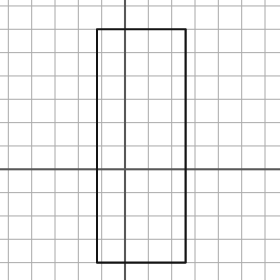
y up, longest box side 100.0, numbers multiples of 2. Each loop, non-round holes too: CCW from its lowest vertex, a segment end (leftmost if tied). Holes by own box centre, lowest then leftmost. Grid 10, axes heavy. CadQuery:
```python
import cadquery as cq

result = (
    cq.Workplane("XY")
    .moveTo(-12.0, -40.0)
    .lineTo(26.0, -40.0)
    .lineTo(26.0, 60.0)
    .lineTo(-12.0, 60.0)
    .close()
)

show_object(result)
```